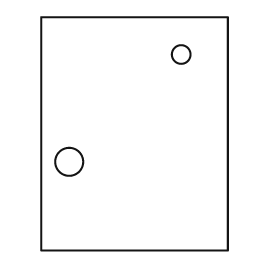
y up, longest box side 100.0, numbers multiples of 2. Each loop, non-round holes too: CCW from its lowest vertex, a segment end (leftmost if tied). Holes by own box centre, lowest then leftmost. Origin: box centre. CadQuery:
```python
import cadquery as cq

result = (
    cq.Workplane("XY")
    .moveTo(-40.0, -50.0)
    .lineTo(40.0, -50.0)
    .lineTo(40.0, 50.0)
    .lineTo(-40.0, 50.0)
    .close()
    .moveTo(-28.0, -12.0)
    .circle(6.0)
    .moveTo(20.0, 34.0)
    .circle(4.0)
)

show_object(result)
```